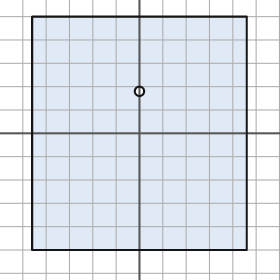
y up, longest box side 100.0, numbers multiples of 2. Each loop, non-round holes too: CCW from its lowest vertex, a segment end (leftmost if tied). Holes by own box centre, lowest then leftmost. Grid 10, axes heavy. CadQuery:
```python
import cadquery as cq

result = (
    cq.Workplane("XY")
    .moveTo(-46.0, -50.0)
    .lineTo(46.0, -50.0)
    .lineTo(46.0, 50.0)
    .lineTo(-46.0, 50.0)
    .close()
    .moveTo(0.0, 18.0)
    .circle(2.0)
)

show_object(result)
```